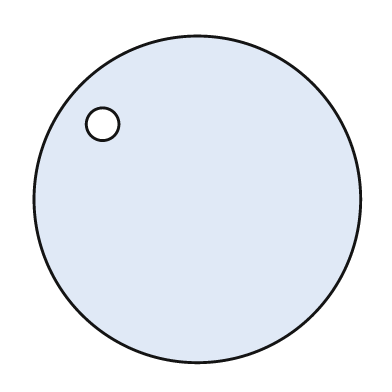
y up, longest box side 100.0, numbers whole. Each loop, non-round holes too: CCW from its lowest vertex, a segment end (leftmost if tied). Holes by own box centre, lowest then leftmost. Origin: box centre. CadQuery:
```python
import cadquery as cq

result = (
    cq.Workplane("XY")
    .moveTo(0.0, 0.0)
    .circle(50.0)
    .moveTo(-29.0, 23.0)
    .circle(5.0)
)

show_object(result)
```